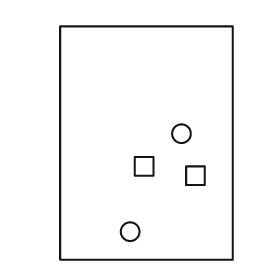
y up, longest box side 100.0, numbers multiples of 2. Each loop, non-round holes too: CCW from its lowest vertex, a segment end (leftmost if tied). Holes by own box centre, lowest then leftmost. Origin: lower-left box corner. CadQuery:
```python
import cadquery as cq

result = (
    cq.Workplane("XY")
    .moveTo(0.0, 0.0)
    .lineTo(74.0, 0.0)
    .lineTo(74.0, 100.0)
    .lineTo(0.0, 100.0)
    .close()
    .moveTo(30.0, 12.0)
    .circle(4.0)
    .moveTo(54.0, 32.0)
    .lineTo(62.0, 32.0)
    .lineTo(62.0, 40.0)
    .lineTo(54.0, 40.0)
    .close()
    .moveTo(32.0, 36.0)
    .lineTo(40.0, 36.0)
    .lineTo(40.0, 44.0)
    .lineTo(32.0, 44.0)
    .close()
    .moveTo(52.0, 54.0)
    .circle(4.0)
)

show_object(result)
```